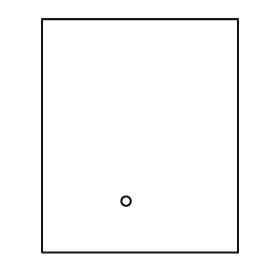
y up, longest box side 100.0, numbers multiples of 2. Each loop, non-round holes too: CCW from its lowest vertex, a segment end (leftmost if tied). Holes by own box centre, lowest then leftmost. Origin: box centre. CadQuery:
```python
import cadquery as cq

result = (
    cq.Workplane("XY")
    .moveTo(-42.0, -50.0)
    .lineTo(42.0, -50.0)
    .lineTo(42.0, 50.0)
    .lineTo(-42.0, 50.0)
    .close()
    .moveTo(-6.0, -28.0)
    .circle(2.0)
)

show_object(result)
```